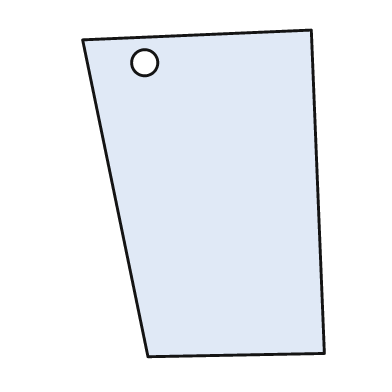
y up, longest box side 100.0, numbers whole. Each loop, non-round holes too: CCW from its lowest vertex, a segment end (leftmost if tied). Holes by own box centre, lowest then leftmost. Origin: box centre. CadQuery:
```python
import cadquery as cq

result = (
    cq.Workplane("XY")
    .moveTo(-17.0, -50.0)
    .lineTo(37.0, -49.0)
    .lineTo(33.0, 50.0)
    .lineTo(-37.0, 47.0)
    .close()
    .moveTo(-18.0, 40.0)
    .circle(4.0)
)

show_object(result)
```